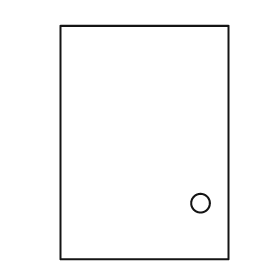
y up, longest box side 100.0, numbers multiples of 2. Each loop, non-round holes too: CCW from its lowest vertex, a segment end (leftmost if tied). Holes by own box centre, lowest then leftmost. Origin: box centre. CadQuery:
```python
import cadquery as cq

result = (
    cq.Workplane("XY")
    .moveTo(-36.0, -50.0)
    .lineTo(36.0, -50.0)
    .lineTo(36.0, 50.0)
    .lineTo(-36.0, 50.0)
    .close()
    .moveTo(24.0, -26.0)
    .circle(4.0)
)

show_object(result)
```